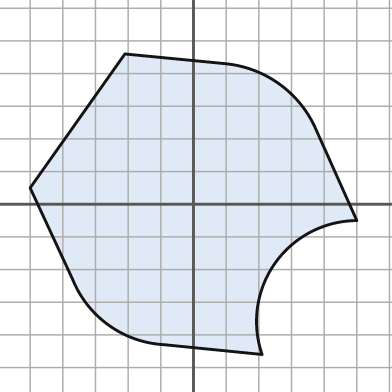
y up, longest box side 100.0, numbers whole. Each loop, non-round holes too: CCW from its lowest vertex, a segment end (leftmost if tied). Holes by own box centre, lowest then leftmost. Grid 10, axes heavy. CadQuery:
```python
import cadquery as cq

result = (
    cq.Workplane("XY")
    .moveTo(21.0, -46.0)
    .threePointArc((25.0, -18.0), (50.0, -5.0))
    .lineTo(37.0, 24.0)
    .threePointArc((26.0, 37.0), (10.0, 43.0))
    .lineTo(-21.0, 46.0)
    .lineTo(-50.0, 5.0)
    .lineTo(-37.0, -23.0)
    .threePointArc((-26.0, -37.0), (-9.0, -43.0))
    .close()
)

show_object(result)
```